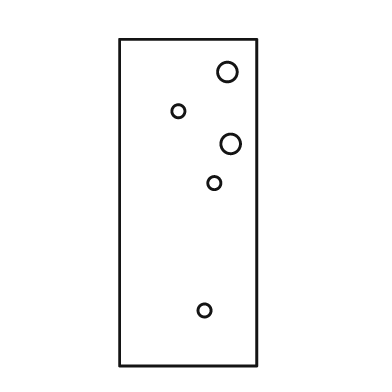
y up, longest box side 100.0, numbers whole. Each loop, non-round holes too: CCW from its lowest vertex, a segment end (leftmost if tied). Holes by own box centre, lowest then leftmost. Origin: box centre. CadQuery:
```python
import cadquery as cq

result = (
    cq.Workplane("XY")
    .moveTo(-21.0, -50.0)
    .lineTo(21.0, -50.0)
    .lineTo(21.0, 50.0)
    .lineTo(-21.0, 50.0)
    .close()
    .moveTo(5.0, -33.0)
    .circle(2.0)
    .moveTo(8.0, 6.0)
    .circle(2.0)
    .moveTo(13.0, 18.0)
    .circle(3.0)
    .moveTo(-3.0, 28.0)
    .circle(2.0)
    .moveTo(12.0, 40.0)
    .circle(3.0)
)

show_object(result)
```